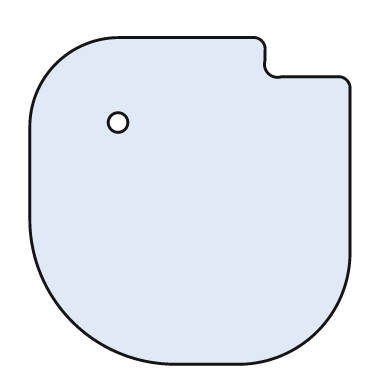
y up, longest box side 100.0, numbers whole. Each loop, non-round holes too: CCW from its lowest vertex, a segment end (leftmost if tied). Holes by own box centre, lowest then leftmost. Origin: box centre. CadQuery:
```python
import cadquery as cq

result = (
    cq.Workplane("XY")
    .moveTo(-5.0, -50.0)
    .lineTo(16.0, -50.0)
    .threePointArc((39.0, -40.0), (49.0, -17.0))
    .lineTo(49.0, 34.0)
    .threePointArc((48.0, 37.0), (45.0, 38.0))
    .lineTo(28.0, 38.0)
    .threePointArc((24.0, 39.0), (23.0, 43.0))
    .lineTo(23.0, 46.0)
    .threePointArc((22.0, 49.0), (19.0, 50.0))
    .lineTo(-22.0, 50.0)
    .threePointArc((-41.0, 42.0), (-49.0, 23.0))
    .lineTo(-49.0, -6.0)
    .threePointArc((-36.0, -37.0), (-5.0, -50.0))
    .close()
    .moveTo(-22.0, 24.0)
    .circle(3.0)
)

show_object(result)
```